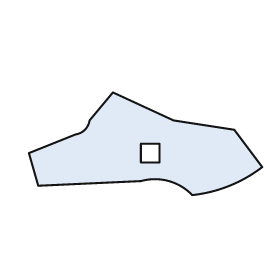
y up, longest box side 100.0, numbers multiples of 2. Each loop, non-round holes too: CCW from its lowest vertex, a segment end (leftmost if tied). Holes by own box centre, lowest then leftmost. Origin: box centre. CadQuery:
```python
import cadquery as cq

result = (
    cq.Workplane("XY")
    .moveTo(20.0, -22.0)
    .threePointArc((36.0, -18.0), (50.0, -10.0))
    .lineTo(38.0, 6.0)
    .lineTo(12.0, 10.0)
    .lineTo(-14.0, 22.0)
    .lineTo(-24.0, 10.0)
    .threePointArc((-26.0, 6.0), (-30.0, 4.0))
    .lineTo(-50.0, -4.0)
    .lineTo(-46.0, -18.0)
    .lineTo(-2.0, -16.0)
    .threePointArc((10.0, -16.0), (20.0, -22.0))
    .close()
    .moveTo(-2.0, -8.0)
    .lineTo(6.0, -8.0)
    .lineTo(6.0, 0.0)
    .lineTo(-2.0, 0.0)
    .close()
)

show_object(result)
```